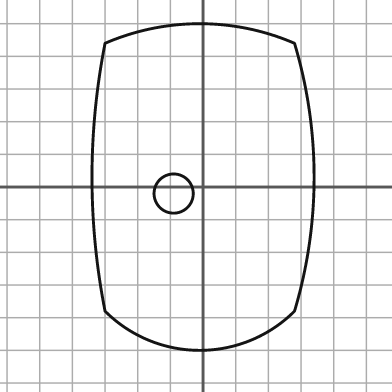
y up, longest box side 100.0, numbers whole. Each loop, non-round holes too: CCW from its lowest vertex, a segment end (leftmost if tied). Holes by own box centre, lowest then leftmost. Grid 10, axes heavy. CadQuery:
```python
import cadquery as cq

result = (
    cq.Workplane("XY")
    .moveTo(-30.0, -38.0)
    .threePointArc((-1.0, -50.0), (28.0, -38.0))
    .threePointArc((34.0, 3.0), (28.0, 44.0))
    .threePointArc((-1.0, 50.0), (-30.0, 44.0))
    .threePointArc((-34.0, 3.0), (-30.0, -38.0))
    .close()
    .moveTo(-9.0, -2.0)
    .circle(6.0)
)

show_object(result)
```